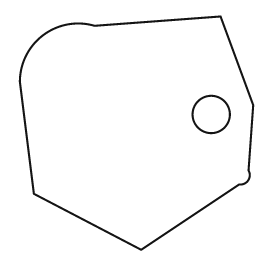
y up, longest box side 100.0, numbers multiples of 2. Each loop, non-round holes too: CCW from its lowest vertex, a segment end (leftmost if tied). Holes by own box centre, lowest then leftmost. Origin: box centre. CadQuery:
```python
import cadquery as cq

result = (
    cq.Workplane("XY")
    .moveTo(2.0, -50.0)
    .lineTo(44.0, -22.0)
    .threePointArc((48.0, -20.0), (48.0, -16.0))
    .lineTo(50.0, 12.0)
    .lineTo(36.0, 50.0)
    .lineTo(-18.0, 46.0)
    .threePointArc((-40.0, 42.0), (-50.0, 22.0))
    .lineTo(-44.0, -26.0)
    .close()
    .moveTo(32.0, 8.0)
    .circle(8.0)
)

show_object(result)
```